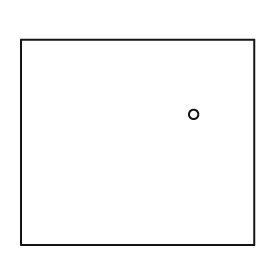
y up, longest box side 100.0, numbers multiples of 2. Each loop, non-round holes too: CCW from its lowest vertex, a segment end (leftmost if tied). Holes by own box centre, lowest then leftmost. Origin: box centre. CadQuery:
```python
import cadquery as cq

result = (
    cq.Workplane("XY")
    .moveTo(-50.0, -44.0)
    .lineTo(50.0, -44.0)
    .lineTo(50.0, 44.0)
    .lineTo(-50.0, 44.0)
    .close()
    .moveTo(24.0, 12.0)
    .circle(2.0)
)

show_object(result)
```